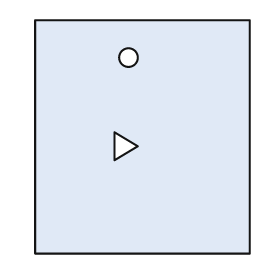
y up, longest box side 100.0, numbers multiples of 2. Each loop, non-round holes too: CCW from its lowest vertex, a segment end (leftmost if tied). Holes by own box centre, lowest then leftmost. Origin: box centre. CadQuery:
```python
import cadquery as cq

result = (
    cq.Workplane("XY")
    .moveTo(-46.0, -50.0)
    .lineTo(46.0, -50.0)
    .lineTo(46.0, 50.0)
    .lineTo(-46.0, 50.0)
    .close()
    .moveTo(-12.0, -10.0)
    .lineTo(-2.0, -4.0)
    .lineTo(-12.0, 2.0)
    .close()
    .moveTo(-6.0, 34.0)
    .circle(4.0)
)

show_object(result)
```